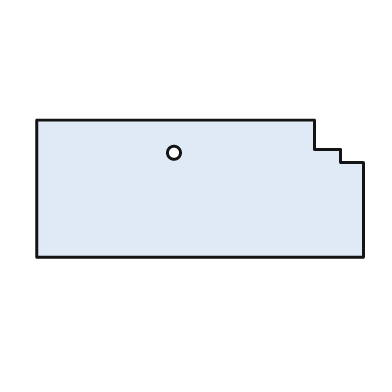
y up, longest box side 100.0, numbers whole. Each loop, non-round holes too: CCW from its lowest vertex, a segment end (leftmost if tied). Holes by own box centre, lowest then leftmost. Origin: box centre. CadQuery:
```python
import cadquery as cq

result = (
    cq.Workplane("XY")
    .moveTo(-50.0, -21.0)
    .lineTo(50.0, -21.0)
    .lineTo(50.0, 8.0)
    .lineTo(43.0, 8.0)
    .lineTo(43.0, 12.0)
    .lineTo(35.0, 12.0)
    .lineTo(35.0, 21.0)
    .lineTo(-50.0, 21.0)
    .close()
    .moveTo(-8.0, 11.0)
    .circle(2.0)
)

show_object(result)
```